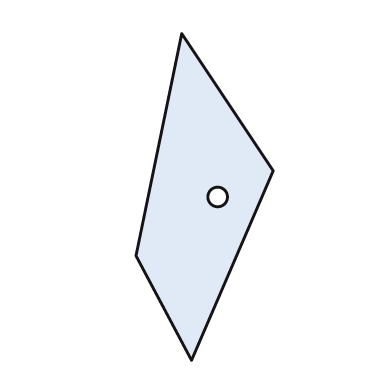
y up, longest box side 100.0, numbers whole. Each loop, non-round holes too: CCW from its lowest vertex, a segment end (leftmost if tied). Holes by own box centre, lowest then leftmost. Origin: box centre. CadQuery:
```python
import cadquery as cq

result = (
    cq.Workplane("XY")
    .moveTo(-4.0, -50.0)
    .lineTo(21.0, 8.0)
    .lineTo(-7.0, 50.0)
    .lineTo(-21.0, -18.0)
    .close()
    .moveTo(4.0, 0.0)
    .circle(3.0)
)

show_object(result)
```